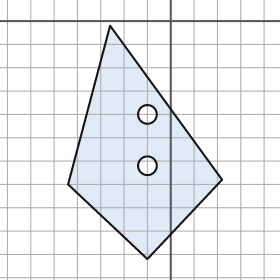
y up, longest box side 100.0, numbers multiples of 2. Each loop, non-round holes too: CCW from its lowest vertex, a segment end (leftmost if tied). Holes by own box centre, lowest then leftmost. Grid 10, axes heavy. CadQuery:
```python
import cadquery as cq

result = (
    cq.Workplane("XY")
    .moveTo(-10.0, -102.0)
    .lineTo(22.0, -68.0)
    .lineTo(-26.0, -2.0)
    .lineTo(-44.0, -70.0)
    .close()
    .moveTo(-10.0, -62.0)
    .circle(4.0)
    .moveTo(-10.0, -40.0)
    .circle(4.0)
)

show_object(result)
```